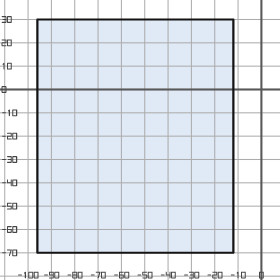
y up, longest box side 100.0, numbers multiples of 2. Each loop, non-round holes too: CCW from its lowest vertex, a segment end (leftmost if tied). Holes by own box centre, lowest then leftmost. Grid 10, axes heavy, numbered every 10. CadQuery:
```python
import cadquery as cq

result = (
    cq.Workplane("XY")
    .moveTo(-96.0, -70.0)
    .lineTo(-12.0, -70.0)
    .lineTo(-12.0, 30.0)
    .lineTo(-96.0, 30.0)
    .close()
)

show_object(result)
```